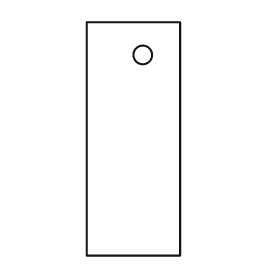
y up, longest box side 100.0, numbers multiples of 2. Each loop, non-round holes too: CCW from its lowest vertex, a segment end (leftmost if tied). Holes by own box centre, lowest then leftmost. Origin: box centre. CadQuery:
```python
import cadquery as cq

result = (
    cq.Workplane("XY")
    .moveTo(-20.0, -50.0)
    .lineTo(20.0, -50.0)
    .lineTo(20.0, 50.0)
    .lineTo(-20.0, 50.0)
    .close()
    .moveTo(4.0, 36.0)
    .circle(4.0)
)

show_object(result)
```